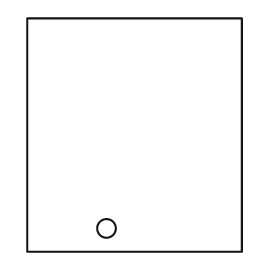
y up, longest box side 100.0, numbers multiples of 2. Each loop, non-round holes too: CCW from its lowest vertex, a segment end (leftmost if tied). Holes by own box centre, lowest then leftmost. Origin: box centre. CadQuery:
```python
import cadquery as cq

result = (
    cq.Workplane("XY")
    .moveTo(-46.0, -50.0)
    .lineTo(46.0, -50.0)
    .lineTo(46.0, 50.0)
    .lineTo(-46.0, 50.0)
    .close()
    .moveTo(-12.0, -40.0)
    .circle(4.0)
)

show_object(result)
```